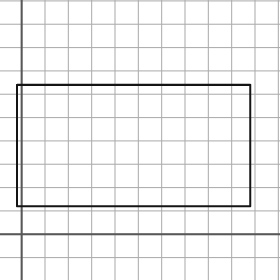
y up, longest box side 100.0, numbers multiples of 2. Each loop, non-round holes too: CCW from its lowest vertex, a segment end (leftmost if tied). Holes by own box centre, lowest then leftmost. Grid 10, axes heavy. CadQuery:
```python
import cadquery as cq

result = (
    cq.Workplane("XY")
    .moveTo(-2.0, 12.0)
    .lineTo(98.0, 12.0)
    .lineTo(98.0, 64.0)
    .lineTo(-2.0, 64.0)
    .close()
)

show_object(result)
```